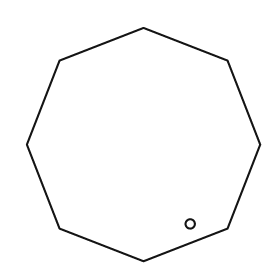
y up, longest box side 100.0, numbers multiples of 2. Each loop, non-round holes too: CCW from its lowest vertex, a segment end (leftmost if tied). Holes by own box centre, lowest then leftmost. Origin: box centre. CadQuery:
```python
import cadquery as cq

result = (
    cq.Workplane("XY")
    .moveTo(0.0, -50.0)
    .lineTo(36.0, -36.0)
    .lineTo(50.0, 0.0)
    .lineTo(36.0, 36.0)
    .lineTo(0.0, 50.0)
    .lineTo(-36.0, 36.0)
    .lineTo(-50.0, 0.0)
    .lineTo(-36.0, -36.0)
    .close()
    .moveTo(20.0, -34.0)
    .circle(2.0)
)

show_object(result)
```